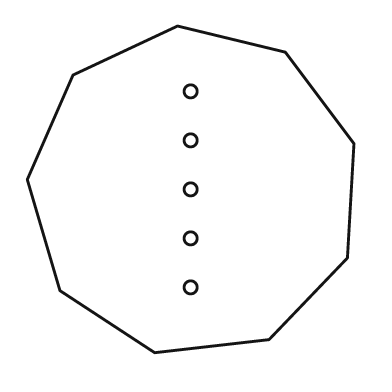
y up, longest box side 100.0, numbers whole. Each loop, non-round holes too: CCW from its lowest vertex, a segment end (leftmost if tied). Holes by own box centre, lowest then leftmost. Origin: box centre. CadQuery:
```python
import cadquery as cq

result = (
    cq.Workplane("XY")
    .moveTo(-11.0, -50.0)
    .lineTo(24.0, -46.0)
    .lineTo(48.0, -21.0)
    .lineTo(50.0, 14.0)
    .lineTo(29.0, 42.0)
    .lineTo(-4.0, 50.0)
    .lineTo(-36.0, 35.0)
    .lineTo(-50.0, 3.0)
    .lineTo(-40.0, -31.0)
    .close()
    .moveTo(0.0, -30.0)
    .circle(2.0)
    .moveTo(0.0, -15.0)
    .circle(2.0)
    .moveTo(0.0, 0.0)
    .circle(2.0)
    .moveTo(0.0, 15.0)
    .circle(2.0)
    .moveTo(0.0, 30.0)
    .circle(2.0)
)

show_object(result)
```